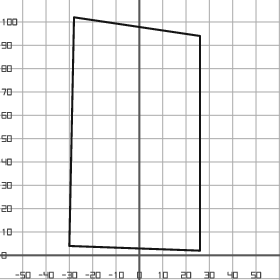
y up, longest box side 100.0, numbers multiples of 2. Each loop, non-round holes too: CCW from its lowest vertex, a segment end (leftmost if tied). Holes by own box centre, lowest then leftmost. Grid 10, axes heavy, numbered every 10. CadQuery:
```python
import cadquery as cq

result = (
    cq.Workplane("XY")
    .moveTo(26.0, 2.0)
    .lineTo(26.0, 94.0)
    .lineTo(-28.0, 102.0)
    .lineTo(-30.0, 4.0)
    .close()
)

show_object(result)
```